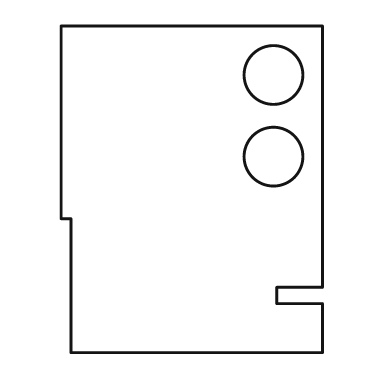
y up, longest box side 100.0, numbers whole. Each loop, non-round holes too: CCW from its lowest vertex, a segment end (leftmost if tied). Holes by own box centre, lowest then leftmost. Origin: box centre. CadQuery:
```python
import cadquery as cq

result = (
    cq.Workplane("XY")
    .moveTo(-37.0, -50.0)
    .lineTo(40.0, -50.0)
    .lineTo(40.0, -35.0)
    .lineTo(26.0, -35.0)
    .lineTo(26.0, -30.0)
    .lineTo(40.0, -30.0)
    .lineTo(40.0, 50.0)
    .lineTo(-40.0, 50.0)
    .lineTo(-40.0, -9.0)
    .lineTo(-37.0, -9.0)
    .close()
    .moveTo(25.0, 10.0)
    .circle(9.0)
    .moveTo(25.0, 35.0)
    .circle(9.0)
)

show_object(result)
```